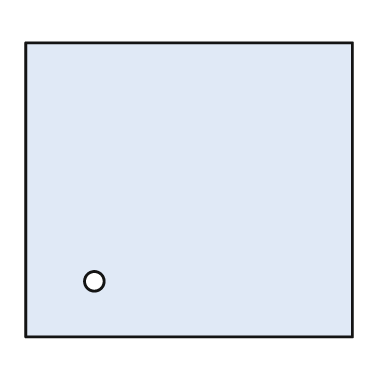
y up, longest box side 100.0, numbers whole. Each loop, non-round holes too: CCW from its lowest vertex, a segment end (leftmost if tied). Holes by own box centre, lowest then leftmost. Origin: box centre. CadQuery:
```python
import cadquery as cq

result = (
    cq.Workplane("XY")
    .moveTo(-50.0, -45.0)
    .lineTo(50.0, -45.0)
    .lineTo(50.0, 45.0)
    .lineTo(-50.0, 45.0)
    .close()
    .moveTo(-29.0, -28.0)
    .circle(3.0)
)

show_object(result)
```